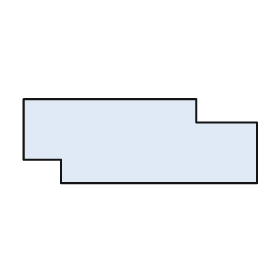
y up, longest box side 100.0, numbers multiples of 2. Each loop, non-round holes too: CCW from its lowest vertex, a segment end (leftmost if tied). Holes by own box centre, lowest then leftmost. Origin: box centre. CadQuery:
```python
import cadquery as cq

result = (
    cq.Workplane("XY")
    .moveTo(-34.0, -18.0)
    .lineTo(50.0, -18.0)
    .lineTo(50.0, 8.0)
    .lineTo(24.0, 8.0)
    .lineTo(24.0, 18.0)
    .lineTo(-50.0, 18.0)
    .lineTo(-50.0, -8.0)
    .lineTo(-34.0, -8.0)
    .close()
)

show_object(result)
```